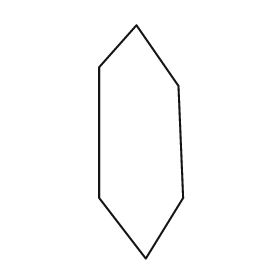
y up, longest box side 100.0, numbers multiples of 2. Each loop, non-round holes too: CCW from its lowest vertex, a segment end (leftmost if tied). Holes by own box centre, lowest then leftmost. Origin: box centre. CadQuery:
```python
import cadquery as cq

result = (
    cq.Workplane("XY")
    .moveTo(2.0, -50.0)
    .lineTo(18.0, -24.0)
    .lineTo(16.0, 24.0)
    .lineTo(-2.0, 50.0)
    .lineTo(-18.0, 32.0)
    .lineTo(-18.0, -24.0)
    .close()
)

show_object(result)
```